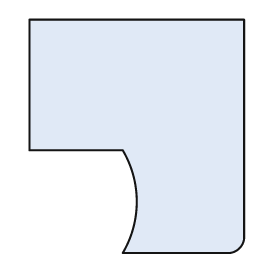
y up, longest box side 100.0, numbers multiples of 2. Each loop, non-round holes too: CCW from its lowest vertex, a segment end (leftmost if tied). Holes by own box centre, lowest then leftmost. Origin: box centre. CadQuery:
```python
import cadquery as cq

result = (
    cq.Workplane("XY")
    .moveTo(-6.0, -50.0)
    .lineTo(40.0, -50.0)
    .threePointArc((44.0, -48.0), (46.0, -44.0))
    .lineTo(46.0, 50.0)
    .lineTo(-46.0, 50.0)
    .lineTo(-46.0, -6.0)
    .lineTo(-6.0, -6.0)
    .threePointArc((0.0, -28.0), (-6.0, -50.0))
    .close()
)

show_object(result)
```